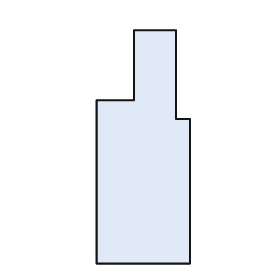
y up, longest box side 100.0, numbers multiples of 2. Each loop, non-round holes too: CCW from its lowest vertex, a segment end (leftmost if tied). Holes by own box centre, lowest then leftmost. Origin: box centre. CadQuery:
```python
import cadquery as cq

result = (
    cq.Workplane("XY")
    .moveTo(-20.0, -50.0)
    .lineTo(20.0, -50.0)
    .lineTo(20.0, 12.0)
    .lineTo(14.0, 12.0)
    .lineTo(14.0, 50.0)
    .lineTo(-4.0, 50.0)
    .lineTo(-4.0, 20.0)
    .lineTo(-20.0, 20.0)
    .close()
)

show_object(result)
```